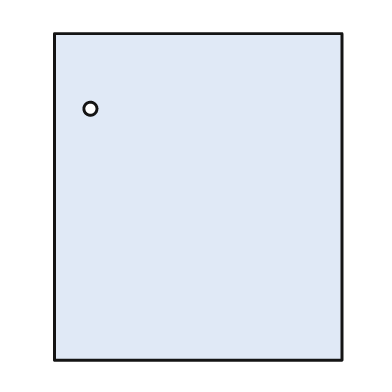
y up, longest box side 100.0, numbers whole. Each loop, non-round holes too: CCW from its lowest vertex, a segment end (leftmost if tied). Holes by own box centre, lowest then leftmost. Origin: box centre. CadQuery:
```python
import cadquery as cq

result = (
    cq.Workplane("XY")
    .moveTo(-44.0, -50.0)
    .lineTo(44.0, -50.0)
    .lineTo(44.0, 50.0)
    .lineTo(-44.0, 50.0)
    .close()
    .moveTo(-33.0, 27.0)
    .circle(2.0)
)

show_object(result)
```